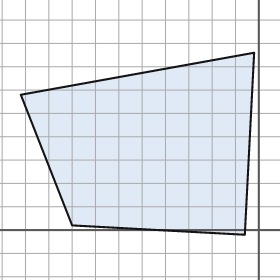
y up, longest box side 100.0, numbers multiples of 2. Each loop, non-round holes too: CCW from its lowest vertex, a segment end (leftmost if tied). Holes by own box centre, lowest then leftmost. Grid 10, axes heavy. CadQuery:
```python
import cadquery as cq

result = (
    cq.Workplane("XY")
    .moveTo(-6.0, -2.0)
    .lineTo(-2.0, 76.0)
    .lineTo(-102.0, 58.0)
    .lineTo(-80.0, 2.0)
    .close()
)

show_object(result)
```